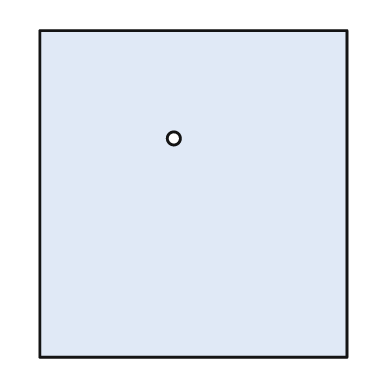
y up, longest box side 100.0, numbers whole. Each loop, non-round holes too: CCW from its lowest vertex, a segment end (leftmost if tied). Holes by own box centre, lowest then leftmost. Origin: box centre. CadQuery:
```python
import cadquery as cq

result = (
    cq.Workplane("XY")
    .moveTo(-47.0, -50.0)
    .lineTo(47.0, -50.0)
    .lineTo(47.0, 50.0)
    .lineTo(-47.0, 50.0)
    .close()
    .moveTo(-6.0, 17.0)
    .circle(2.0)
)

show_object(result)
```